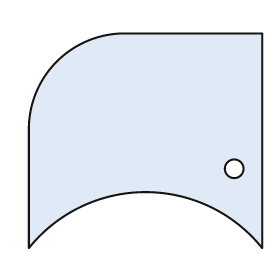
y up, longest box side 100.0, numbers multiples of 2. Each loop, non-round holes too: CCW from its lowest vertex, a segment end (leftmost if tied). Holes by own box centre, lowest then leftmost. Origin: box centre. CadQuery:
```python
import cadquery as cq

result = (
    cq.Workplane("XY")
    .moveTo(-50.0, -46.0)
    .threePointArc((0.0, -22.0), (50.0, -46.0))
    .lineTo(50.0, 46.0)
    .lineTo(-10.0, 46.0)
    .threePointArc((-38.0, 34.0), (-50.0, 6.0))
    .close()
    .moveTo(38.0, -12.0)
    .circle(4.0)
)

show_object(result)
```